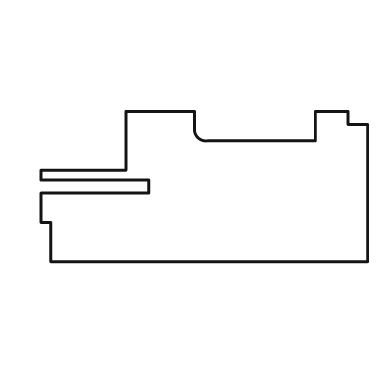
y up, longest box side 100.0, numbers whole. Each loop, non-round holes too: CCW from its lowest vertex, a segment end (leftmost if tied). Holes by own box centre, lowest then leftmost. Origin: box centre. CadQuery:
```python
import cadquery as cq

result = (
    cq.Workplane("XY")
    .moveTo(-47.0, -23.0)
    .lineTo(50.0, -23.0)
    .lineTo(50.0, 19.0)
    .lineTo(44.0, 19.0)
    .lineTo(44.0, 23.0)
    .lineTo(34.0, 23.0)
    .lineTo(34.0, 14.0)
    .lineTo(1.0, 14.0)
    .threePointArc((-2.0, 15.0), (-3.0, 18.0))
    .lineTo(-3.0, 23.0)
    .lineTo(-24.0, 23.0)
    .lineTo(-24.0, 5.0)
    .lineTo(-50.0, 5.0)
    .lineTo(-50.0, 2.0)
    .lineTo(-17.0, 2.0)
    .lineTo(-17.0, -2.0)
    .lineTo(-50.0, -2.0)
    .lineTo(-50.0, -11.0)
    .lineTo(-47.0, -11.0)
    .close()
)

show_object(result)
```